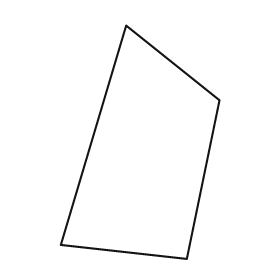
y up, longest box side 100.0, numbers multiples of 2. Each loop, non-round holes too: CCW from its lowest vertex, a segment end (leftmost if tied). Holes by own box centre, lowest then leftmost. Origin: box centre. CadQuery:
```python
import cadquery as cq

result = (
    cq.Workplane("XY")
    .moveTo(20.0, -50.0)
    .lineTo(34.0, 18.0)
    .lineTo(-6.0, 50.0)
    .lineTo(-34.0, -44.0)
    .close()
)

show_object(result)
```